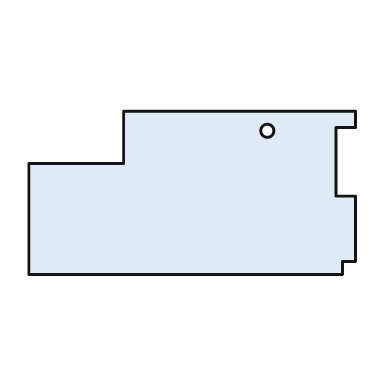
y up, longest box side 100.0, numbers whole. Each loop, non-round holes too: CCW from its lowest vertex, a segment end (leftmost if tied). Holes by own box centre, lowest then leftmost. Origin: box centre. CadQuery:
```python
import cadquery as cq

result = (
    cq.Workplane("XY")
    .moveTo(-50.0, -25.0)
    .lineTo(46.0, -25.0)
    .lineTo(46.0, -21.0)
    .lineTo(50.0, -21.0)
    .lineTo(50.0, -1.0)
    .lineTo(44.0, -1.0)
    .lineTo(44.0, 20.0)
    .lineTo(50.0, 20.0)
    .lineTo(50.0, 25.0)
    .lineTo(-21.0, 25.0)
    .lineTo(-21.0, 9.0)
    .lineTo(-50.0, 9.0)
    .close()
    .moveTo(23.0, 19.0)
    .circle(2.0)
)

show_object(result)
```